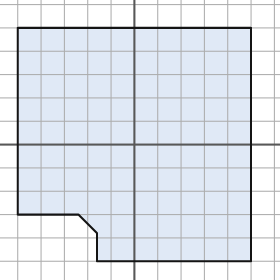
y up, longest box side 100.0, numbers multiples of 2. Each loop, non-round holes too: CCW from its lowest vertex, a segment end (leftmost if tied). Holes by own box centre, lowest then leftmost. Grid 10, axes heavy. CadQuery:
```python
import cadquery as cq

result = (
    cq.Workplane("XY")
    .moveTo(-16.0, -50.0)
    .lineTo(50.0, -50.0)
    .lineTo(50.0, 50.0)
    .lineTo(-50.0, 50.0)
    .lineTo(-50.0, -30.0)
    .lineTo(-24.0, -30.0)
    .lineTo(-16.0, -38.0)
    .close()
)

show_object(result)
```